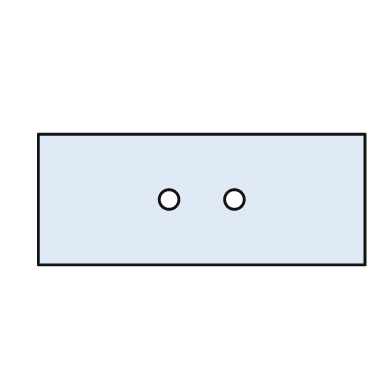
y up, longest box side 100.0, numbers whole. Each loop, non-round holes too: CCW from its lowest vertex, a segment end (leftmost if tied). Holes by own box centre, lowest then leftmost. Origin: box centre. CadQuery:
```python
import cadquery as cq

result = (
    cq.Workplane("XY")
    .moveTo(-50.0, -20.0)
    .lineTo(50.0, -20.0)
    .lineTo(50.0, 20.0)
    .lineTo(-50.0, 20.0)
    .close()
    .moveTo(-10.0, 0.0)
    .circle(3.0)
    .moveTo(10.0, 0.0)
    .circle(3.0)
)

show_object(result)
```